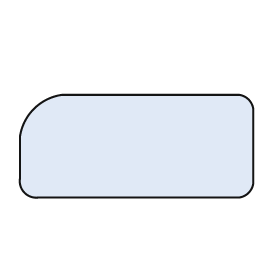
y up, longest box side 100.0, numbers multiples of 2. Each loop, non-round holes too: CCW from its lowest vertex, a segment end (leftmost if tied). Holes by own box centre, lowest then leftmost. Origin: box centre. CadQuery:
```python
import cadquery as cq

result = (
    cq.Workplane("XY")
    .moveTo(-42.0, -22.0)
    .lineTo(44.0, -22.0)
    .threePointArc((48.0, -20.0), (50.0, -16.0))
    .lineTo(50.0, 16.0)
    .threePointArc((48.0, 20.0), (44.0, 22.0))
    .lineTo(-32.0, 22.0)
    .threePointArc((-44.0, 16.0), (-50.0, 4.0))
    .lineTo(-50.0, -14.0)
    .threePointArc((-48.0, -20.0), (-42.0, -22.0))
    .close()
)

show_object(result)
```